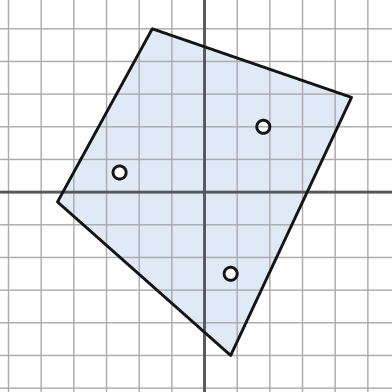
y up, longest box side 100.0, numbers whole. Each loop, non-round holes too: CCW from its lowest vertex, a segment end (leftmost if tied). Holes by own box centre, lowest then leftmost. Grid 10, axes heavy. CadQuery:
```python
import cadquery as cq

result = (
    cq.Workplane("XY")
    .moveTo(8.0, -50.0)
    .lineTo(45.0, 29.0)
    .lineTo(-16.0, 50.0)
    .lineTo(-45.0, -3.0)
    .close()
    .moveTo(8.0, -25.0)
    .circle(2.0)
    .moveTo(-26.0, 6.0)
    .circle(2.0)
    .moveTo(18.0, 20.0)
    .circle(2.0)
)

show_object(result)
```